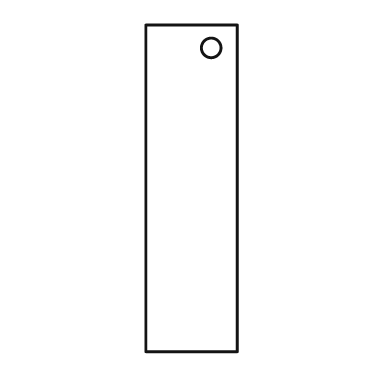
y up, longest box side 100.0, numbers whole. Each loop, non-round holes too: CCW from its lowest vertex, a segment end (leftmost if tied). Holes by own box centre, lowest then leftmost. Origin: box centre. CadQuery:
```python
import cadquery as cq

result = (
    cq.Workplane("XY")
    .moveTo(-14.0, -50.0)
    .lineTo(14.0, -50.0)
    .lineTo(14.0, 50.0)
    .lineTo(-14.0, 50.0)
    .close()
    .moveTo(6.0, 43.0)
    .circle(3.0)
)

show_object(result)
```